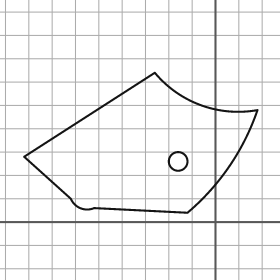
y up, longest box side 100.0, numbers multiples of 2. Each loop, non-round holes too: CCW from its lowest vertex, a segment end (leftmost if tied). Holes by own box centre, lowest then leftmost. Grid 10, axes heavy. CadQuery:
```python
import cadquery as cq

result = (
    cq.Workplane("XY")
    .moveTo(-12.0, 4.0)
    .threePointArc((6.0, 24.0), (18.0, 48.0))
    .threePointArc((-6.0, 50.0), (-26.0, 64.0))
    .lineTo(-82.0, 28.0)
    .lineTo(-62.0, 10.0)
    .threePointArc((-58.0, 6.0), (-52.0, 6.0))
    .close()
    .moveTo(-16.0, 26.0)
    .circle(4.0)
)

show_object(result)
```